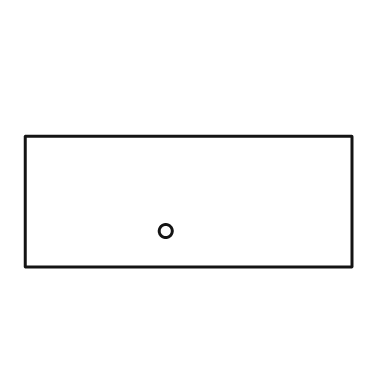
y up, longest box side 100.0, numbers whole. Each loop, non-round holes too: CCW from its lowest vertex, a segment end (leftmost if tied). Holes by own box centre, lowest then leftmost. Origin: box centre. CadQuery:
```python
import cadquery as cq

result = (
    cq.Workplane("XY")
    .moveTo(-50.0, -20.0)
    .lineTo(50.0, -20.0)
    .lineTo(50.0, 20.0)
    .lineTo(-50.0, 20.0)
    .close()
    .moveTo(-7.0, -9.0)
    .circle(2.0)
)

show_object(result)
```